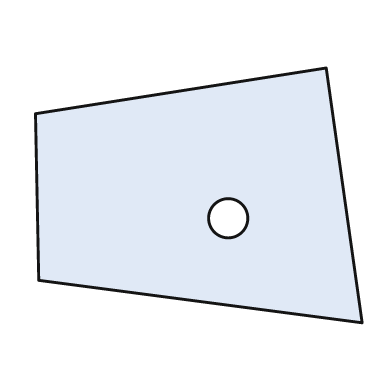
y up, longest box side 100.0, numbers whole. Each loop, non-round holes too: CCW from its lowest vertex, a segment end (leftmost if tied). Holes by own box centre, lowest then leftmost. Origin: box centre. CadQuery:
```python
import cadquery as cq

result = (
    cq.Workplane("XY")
    .moveTo(50.0, -39.0)
    .lineTo(39.0, 39.0)
    .lineTo(-50.0, 25.0)
    .lineTo(-49.0, -26.0)
    .close()
    .moveTo(9.0, -7.0)
    .circle(6.0)
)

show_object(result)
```